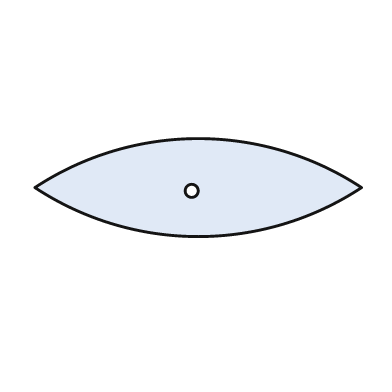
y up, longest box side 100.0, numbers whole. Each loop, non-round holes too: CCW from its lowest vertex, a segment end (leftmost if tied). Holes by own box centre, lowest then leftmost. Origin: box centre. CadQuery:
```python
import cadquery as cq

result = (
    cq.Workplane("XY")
    .moveTo(-50.0, 0.0)
    .threePointArc((0.0, -15.0), (50.0, 0.0))
    .threePointArc((0.0, 15.0), (-50.0, 0.0))
    .close()
    .moveTo(-2.0, -1.0)
    .circle(2.0)
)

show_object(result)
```